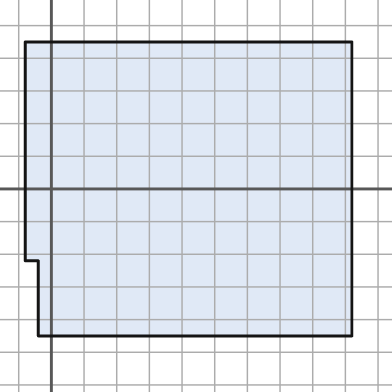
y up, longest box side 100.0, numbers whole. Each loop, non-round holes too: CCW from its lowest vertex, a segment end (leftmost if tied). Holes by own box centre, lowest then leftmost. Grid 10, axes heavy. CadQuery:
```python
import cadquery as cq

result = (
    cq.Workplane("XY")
    .moveTo(-4.0, -45.0)
    .lineTo(92.0, -45.0)
    .lineTo(92.0, 45.0)
    .lineTo(-8.0, 45.0)
    .lineTo(-8.0, -22.0)
    .lineTo(-4.0, -22.0)
    .close()
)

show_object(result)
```